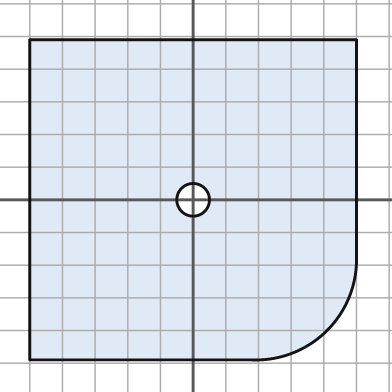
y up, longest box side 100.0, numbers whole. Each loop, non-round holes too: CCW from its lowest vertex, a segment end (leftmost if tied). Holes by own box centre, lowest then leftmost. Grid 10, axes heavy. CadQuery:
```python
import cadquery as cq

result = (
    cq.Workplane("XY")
    .moveTo(-50.0, -49.0)
    .lineTo(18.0, -49.0)
    .threePointArc((41.0, -40.0), (50.0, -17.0))
    .lineTo(50.0, 49.0)
    .lineTo(-50.0, 49.0)
    .close()
    .moveTo(0.0, 0.0)
    .circle(5.0)
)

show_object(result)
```